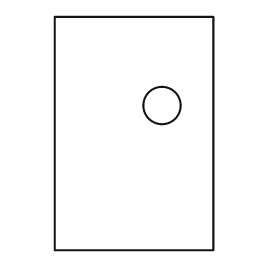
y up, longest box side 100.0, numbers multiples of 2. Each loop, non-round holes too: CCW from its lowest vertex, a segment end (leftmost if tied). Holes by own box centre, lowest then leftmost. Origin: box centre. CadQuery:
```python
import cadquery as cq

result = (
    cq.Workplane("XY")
    .moveTo(-34.0, -50.0)
    .lineTo(34.0, -50.0)
    .lineTo(34.0, 50.0)
    .lineTo(-34.0, 50.0)
    .close()
    .moveTo(12.0, 12.0)
    .circle(8.0)
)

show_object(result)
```